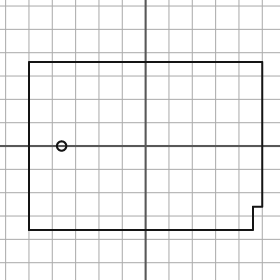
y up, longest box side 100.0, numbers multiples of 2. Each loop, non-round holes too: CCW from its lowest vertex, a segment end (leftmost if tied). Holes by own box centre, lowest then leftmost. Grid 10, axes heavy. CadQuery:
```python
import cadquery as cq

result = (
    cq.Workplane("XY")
    .moveTo(-50.0, -36.0)
    .lineTo(46.0, -36.0)
    .lineTo(46.0, -26.0)
    .lineTo(50.0, -26.0)
    .lineTo(50.0, 36.0)
    .lineTo(-50.0, 36.0)
    .close()
    .moveTo(-36.0, 0.0)
    .circle(2.0)
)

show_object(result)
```